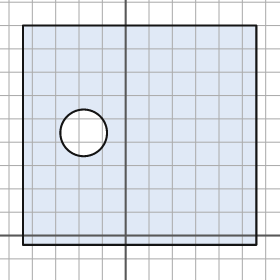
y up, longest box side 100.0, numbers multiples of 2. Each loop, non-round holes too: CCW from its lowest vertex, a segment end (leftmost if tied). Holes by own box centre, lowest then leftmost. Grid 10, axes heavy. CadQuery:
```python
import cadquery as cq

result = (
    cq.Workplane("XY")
    .moveTo(-44.0, -4.0)
    .lineTo(56.0, -4.0)
    .lineTo(56.0, 90.0)
    .lineTo(-44.0, 90.0)
    .close()
    .moveTo(-18.0, 44.0)
    .circle(10.0)
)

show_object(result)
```